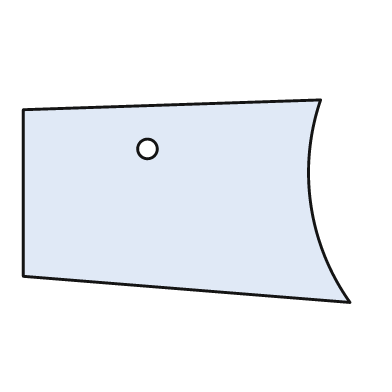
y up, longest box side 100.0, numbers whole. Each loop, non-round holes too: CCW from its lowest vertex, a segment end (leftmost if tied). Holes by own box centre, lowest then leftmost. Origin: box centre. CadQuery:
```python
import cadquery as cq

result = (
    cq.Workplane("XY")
    .moveTo(50.0, -31.0)
    .threePointArc((38.0, -1.0), (41.0, 31.0))
    .lineTo(-50.0, 28.0)
    .lineTo(-50.0, -23.0)
    .close()
    .moveTo(-12.0, 16.0)
    .circle(3.0)
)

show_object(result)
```